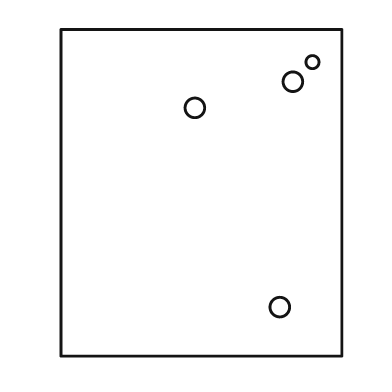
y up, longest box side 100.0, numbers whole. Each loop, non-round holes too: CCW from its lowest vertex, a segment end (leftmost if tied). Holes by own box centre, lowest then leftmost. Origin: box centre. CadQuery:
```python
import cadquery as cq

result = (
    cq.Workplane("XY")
    .moveTo(-43.0, -50.0)
    .lineTo(43.0, -50.0)
    .lineTo(43.0, 50.0)
    .lineTo(-43.0, 50.0)
    .close()
    .moveTo(24.0, -35.0)
    .circle(3.0)
    .moveTo(-2.0, 26.0)
    .circle(3.0)
    .moveTo(28.0, 34.0)
    .circle(3.0)
    .moveTo(34.0, 40.0)
    .circle(2.0)
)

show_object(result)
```